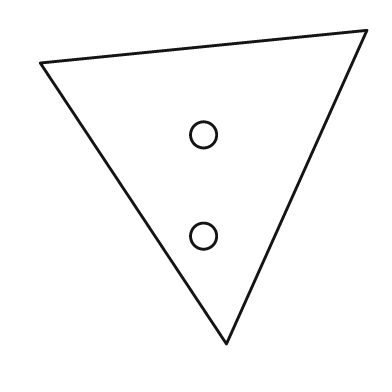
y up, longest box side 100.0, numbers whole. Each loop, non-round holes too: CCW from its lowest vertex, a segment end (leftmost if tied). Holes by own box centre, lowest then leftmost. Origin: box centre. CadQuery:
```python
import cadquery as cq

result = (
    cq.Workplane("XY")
    .moveTo(7.0, -48.0)
    .lineTo(50.0, 48.0)
    .lineTo(-50.0, 38.0)
    .close()
    .moveTo(0.0, -15.0)
    .circle(4.0)
    .moveTo(0.0, 16.0)
    .circle(4.0)
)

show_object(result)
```